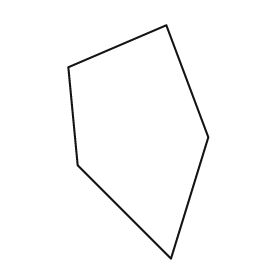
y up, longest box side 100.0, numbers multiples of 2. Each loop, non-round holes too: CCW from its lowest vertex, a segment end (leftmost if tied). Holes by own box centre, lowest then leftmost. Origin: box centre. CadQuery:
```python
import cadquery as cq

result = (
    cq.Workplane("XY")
    .moveTo(14.0, -50.0)
    .lineTo(30.0, 2.0)
    .lineTo(12.0, 50.0)
    .lineTo(-30.0, 32.0)
    .lineTo(-26.0, -10.0)
    .close()
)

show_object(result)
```